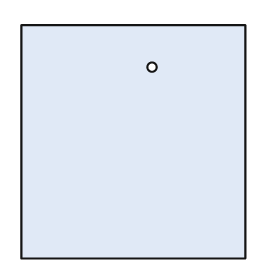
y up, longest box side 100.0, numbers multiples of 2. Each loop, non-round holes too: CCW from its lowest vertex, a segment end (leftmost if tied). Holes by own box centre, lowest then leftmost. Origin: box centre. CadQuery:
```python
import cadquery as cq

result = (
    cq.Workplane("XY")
    .moveTo(-48.0, -50.0)
    .lineTo(48.0, -50.0)
    .lineTo(48.0, 50.0)
    .lineTo(-48.0, 50.0)
    .close()
    .moveTo(8.0, 32.0)
    .circle(2.0)
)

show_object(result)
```